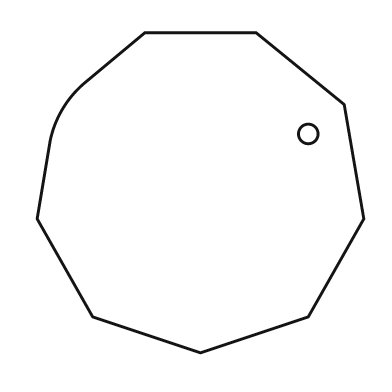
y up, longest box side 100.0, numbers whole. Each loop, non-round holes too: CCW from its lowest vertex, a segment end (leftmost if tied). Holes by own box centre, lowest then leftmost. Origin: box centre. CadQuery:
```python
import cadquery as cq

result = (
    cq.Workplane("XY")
    .moveTo(0.0, -49.0)
    .lineTo(33.0, -38.0)
    .lineTo(50.0, -8.0)
    .lineTo(44.0, 27.0)
    .lineTo(17.0, 49.0)
    .lineTo(-17.0, 49.0)
    .lineTo(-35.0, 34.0)
    .threePointArc((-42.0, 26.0), (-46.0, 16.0))
    .lineTo(-50.0, -8.0)
    .lineTo(-33.0, -38.0)
    .close()
    .moveTo(33.0, 18.0)
    .circle(3.0)
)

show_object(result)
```